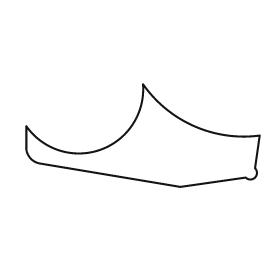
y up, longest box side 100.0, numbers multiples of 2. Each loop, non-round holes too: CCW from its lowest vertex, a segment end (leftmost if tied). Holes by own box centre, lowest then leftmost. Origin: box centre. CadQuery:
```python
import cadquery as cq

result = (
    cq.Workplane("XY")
    .moveTo(16.0, -22.0)
    .lineTo(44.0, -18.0)
    .threePointArc((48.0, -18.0), (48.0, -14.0))
    .lineTo(50.0, 0.0)
    .threePointArc((22.0, 4.0), (0.0, 22.0))
    .threePointArc((-18.0, -6.0), (-50.0, 4.0))
    .lineTo(-50.0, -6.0)
    .threePointArc((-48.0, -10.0), (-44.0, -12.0))
    .close()
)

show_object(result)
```